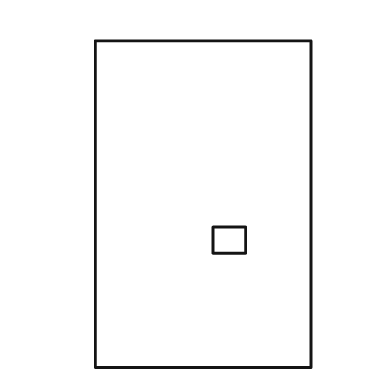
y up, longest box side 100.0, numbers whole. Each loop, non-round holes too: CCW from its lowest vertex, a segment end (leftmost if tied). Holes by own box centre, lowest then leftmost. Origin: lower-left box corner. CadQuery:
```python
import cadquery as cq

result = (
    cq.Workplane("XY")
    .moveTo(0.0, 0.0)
    .lineTo(66.0, 0.0)
    .lineTo(66.0, 100.0)
    .lineTo(0.0, 100.0)
    .close()
    .moveTo(36.0, 35.0)
    .lineTo(46.0, 35.0)
    .lineTo(46.0, 43.0)
    .lineTo(36.0, 43.0)
    .close()
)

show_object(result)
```